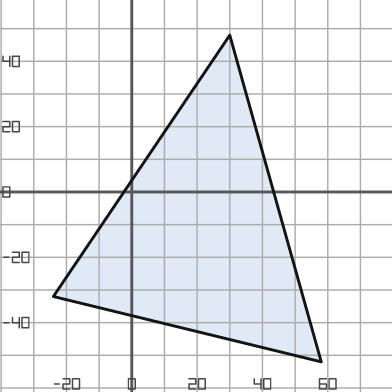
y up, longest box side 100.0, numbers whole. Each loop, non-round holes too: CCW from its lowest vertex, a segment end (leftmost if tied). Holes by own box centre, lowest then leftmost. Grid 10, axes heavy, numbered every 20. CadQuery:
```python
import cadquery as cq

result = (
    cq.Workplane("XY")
    .moveTo(58.0, -52.0)
    .lineTo(30.0, 48.0)
    .lineTo(-24.0, -32.0)
    .close()
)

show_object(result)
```